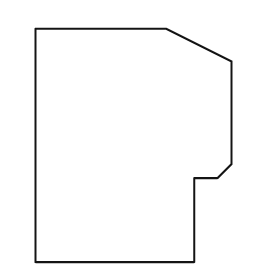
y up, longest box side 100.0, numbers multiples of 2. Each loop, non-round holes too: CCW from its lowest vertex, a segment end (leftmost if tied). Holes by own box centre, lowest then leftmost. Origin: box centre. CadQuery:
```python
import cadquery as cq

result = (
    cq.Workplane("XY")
    .moveTo(-42.0, -50.0)
    .lineTo(26.0, -50.0)
    .lineTo(26.0, -14.0)
    .lineTo(36.0, -14.0)
    .lineTo(42.0, -8.0)
    .lineTo(42.0, 36.0)
    .lineTo(14.0, 50.0)
    .lineTo(-42.0, 50.0)
    .close()
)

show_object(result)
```